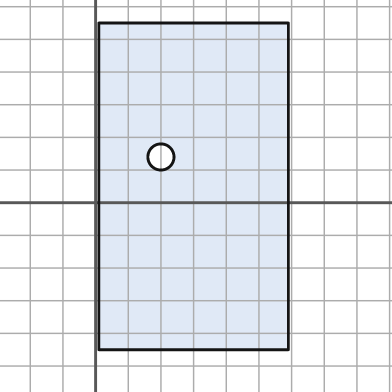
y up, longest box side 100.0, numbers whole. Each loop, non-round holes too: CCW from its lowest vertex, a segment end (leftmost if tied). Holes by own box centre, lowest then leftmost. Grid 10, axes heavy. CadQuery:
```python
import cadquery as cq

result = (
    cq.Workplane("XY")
    .moveTo(1.0, -45.0)
    .lineTo(59.0, -45.0)
    .lineTo(59.0, 55.0)
    .lineTo(1.0, 55.0)
    .close()
    .moveTo(20.0, 14.0)
    .circle(4.0)
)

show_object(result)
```